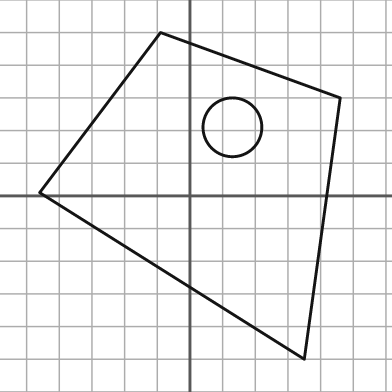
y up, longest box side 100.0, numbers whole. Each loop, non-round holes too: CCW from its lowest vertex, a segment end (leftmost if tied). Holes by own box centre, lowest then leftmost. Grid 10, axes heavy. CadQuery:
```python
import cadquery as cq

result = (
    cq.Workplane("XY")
    .moveTo(35.0, -50.0)
    .lineTo(46.0, 30.0)
    .lineTo(-9.0, 50.0)
    .lineTo(-46.0, 1.0)
    .close()
    .moveTo(13.0, 21.0)
    .circle(9.0)
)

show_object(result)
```